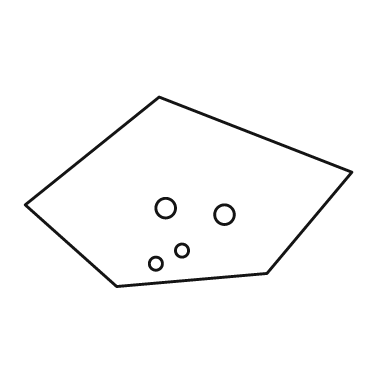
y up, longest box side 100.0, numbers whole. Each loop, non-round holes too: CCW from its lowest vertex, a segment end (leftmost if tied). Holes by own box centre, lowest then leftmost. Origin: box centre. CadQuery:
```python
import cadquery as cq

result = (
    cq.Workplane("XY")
    .moveTo(-22.0, -29.0)
    .lineTo(24.0, -25.0)
    .lineTo(50.0, 6.0)
    .lineTo(-9.0, 29.0)
    .lineTo(-50.0, -4.0)
    .close()
    .moveTo(-10.0, -22.0)
    .circle(2.0)
    .moveTo(-2.0, -18.0)
    .circle(2.0)
    .moveTo(11.0, -7.0)
    .circle(3.0)
    .moveTo(-7.0, -5.0)
    .circle(3.0)
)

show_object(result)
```